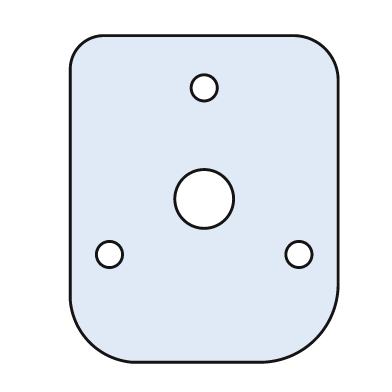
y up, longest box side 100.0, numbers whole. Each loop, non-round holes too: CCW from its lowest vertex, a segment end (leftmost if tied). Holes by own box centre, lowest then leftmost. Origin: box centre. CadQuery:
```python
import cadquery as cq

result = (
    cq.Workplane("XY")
    .moveTo(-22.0, -50.0)
    .lineTo(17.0, -50.0)
    .threePointArc((34.0, -43.0), (41.0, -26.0))
    .lineTo(41.0, 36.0)
    .threePointArc((37.0, 46.0), (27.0, 50.0))
    .lineTo(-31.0, 50.0)
    .threePointArc((-38.0, 47.0), (-41.0, 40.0))
    .lineTo(-41.0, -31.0)
    .threePointArc((-35.0, -44.0), (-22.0, -50.0))
    .close()
    .moveTo(-29.0, -17.0)
    .circle(4.0)
    .moveTo(29.0, -17.0)
    .circle(4.0)
    .moveTo(0.0, 0.0)
    .circle(9.0)
    .moveTo(0.0, 34.0)
    .circle(4.0)
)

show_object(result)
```